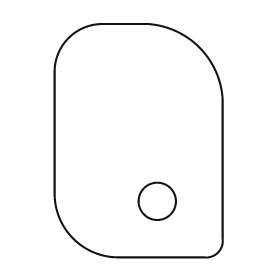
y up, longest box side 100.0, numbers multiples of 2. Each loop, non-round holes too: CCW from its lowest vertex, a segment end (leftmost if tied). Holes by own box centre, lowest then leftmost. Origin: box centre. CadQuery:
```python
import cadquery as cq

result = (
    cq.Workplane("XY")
    .moveTo(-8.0, -50.0)
    .lineTo(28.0, -50.0)
    .threePointArc((34.0, -48.0), (36.0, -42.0))
    .lineTo(36.0, 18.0)
    .threePointArc((26.0, 40.0), (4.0, 50.0))
    .lineTo(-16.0, 50.0)
    .threePointArc((-30.0, 44.0), (-36.0, 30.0))
    .lineTo(-36.0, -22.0)
    .threePointArc((-28.0, -42.0), (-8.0, -50.0))
    .close()
    .moveTo(8.0, -26.0)
    .circle(8.0)
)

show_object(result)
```